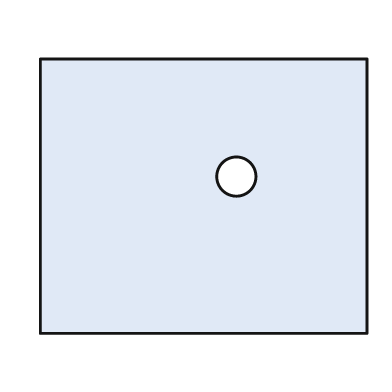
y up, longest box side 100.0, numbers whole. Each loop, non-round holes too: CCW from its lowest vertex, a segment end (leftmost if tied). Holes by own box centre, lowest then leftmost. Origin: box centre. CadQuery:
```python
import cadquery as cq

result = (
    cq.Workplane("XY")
    .moveTo(-50.0, -42.0)
    .lineTo(50.0, -42.0)
    .lineTo(50.0, 42.0)
    .lineTo(-50.0, 42.0)
    .close()
    .moveTo(10.0, 6.0)
    .circle(6.0)
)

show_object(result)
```